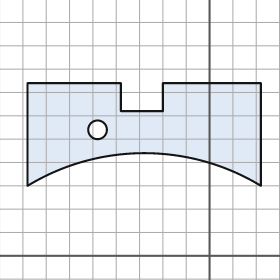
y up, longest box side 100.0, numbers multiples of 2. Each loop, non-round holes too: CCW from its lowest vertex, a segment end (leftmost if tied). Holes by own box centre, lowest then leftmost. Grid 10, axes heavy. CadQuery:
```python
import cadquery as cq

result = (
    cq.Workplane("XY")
    .moveTo(-78.0, 30.0)
    .threePointArc((-28.0, 44.0), (22.0, 30.0))
    .lineTo(22.0, 74.0)
    .lineTo(-20.0, 74.0)
    .lineTo(-20.0, 62.0)
    .lineTo(-38.0, 62.0)
    .lineTo(-38.0, 74.0)
    .lineTo(-78.0, 74.0)
    .close()
    .moveTo(-48.0, 54.0)
    .circle(4.0)
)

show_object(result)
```